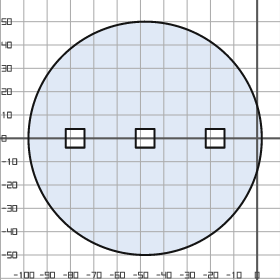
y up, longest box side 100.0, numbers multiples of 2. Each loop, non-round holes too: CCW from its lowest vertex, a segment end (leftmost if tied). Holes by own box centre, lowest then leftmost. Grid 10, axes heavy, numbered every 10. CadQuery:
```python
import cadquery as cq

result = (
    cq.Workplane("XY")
    .moveTo(-48.0, 0.0)
    .circle(50.0)
    .moveTo(-82.0, -4.0)
    .lineTo(-74.0, -4.0)
    .lineTo(-74.0, 4.0)
    .lineTo(-82.0, 4.0)
    .close()
    .moveTo(-52.0, -4.0)
    .lineTo(-44.0, -4.0)
    .lineTo(-44.0, 4.0)
    .lineTo(-52.0, 4.0)
    .close()
    .moveTo(-22.0, -4.0)
    .lineTo(-14.0, -4.0)
    .lineTo(-14.0, 4.0)
    .lineTo(-22.0, 4.0)
    .close()
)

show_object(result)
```